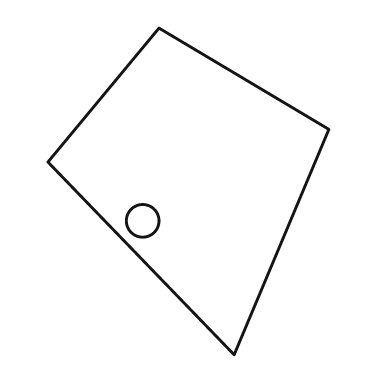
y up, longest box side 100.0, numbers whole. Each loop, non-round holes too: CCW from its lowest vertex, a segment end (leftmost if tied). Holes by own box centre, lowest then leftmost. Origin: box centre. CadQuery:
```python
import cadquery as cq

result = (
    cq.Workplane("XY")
    .moveTo(14.0, -50.0)
    .lineTo(43.0, 19.0)
    .lineTo(-9.0, 50.0)
    .lineTo(-43.0, 9.0)
    .close()
    .moveTo(-14.0, -9.0)
    .circle(5.0)
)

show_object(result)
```